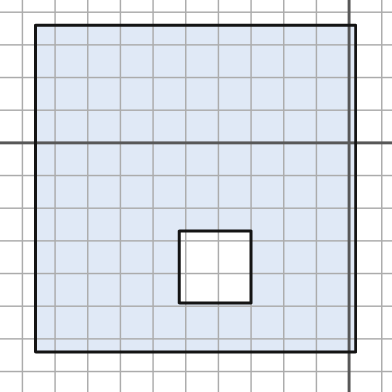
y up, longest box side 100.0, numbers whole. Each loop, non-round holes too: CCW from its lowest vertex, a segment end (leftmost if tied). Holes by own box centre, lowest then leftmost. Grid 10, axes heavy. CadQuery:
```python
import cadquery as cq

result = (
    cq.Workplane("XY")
    .moveTo(-96.0, -64.0)
    .lineTo(2.0, -64.0)
    .lineTo(2.0, 36.0)
    .lineTo(-96.0, 36.0)
    .close()
    .moveTo(-52.0, -49.0)
    .lineTo(-30.0, -49.0)
    .lineTo(-30.0, -27.0)
    .lineTo(-52.0, -27.0)
    .close()
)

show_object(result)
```